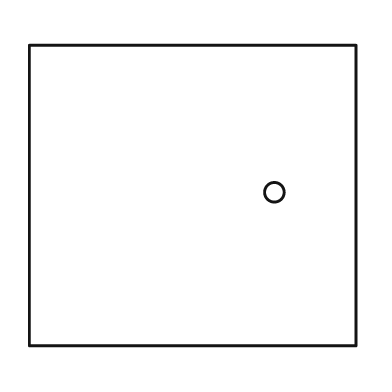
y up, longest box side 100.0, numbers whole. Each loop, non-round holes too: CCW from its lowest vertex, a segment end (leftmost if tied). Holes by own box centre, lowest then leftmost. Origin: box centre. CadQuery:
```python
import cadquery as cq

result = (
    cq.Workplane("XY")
    .moveTo(-50.0, -46.0)
    .lineTo(50.0, -46.0)
    .lineTo(50.0, 46.0)
    .lineTo(-50.0, 46.0)
    .close()
    .moveTo(25.0, 1.0)
    .circle(3.0)
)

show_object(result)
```